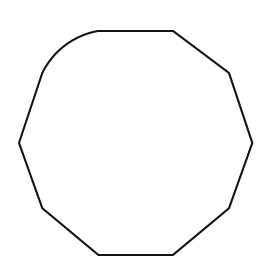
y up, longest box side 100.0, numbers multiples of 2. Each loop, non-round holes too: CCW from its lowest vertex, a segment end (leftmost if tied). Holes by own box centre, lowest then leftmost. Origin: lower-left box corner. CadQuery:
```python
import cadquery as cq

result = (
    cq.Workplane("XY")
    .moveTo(34.0, 0.0)
    .lineTo(66.0, 0.0)
    .lineTo(90.0, 20.0)
    .lineTo(100.0, 48.0)
    .lineTo(90.0, 78.0)
    .lineTo(66.0, 96.0)
    .lineTo(34.0, 96.0)
    .threePointArc((20.0, 90.0), (10.0, 78.0))
    .lineTo(0.0, 48.0)
    .lineTo(10.0, 20.0)
    .close()
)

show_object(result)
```